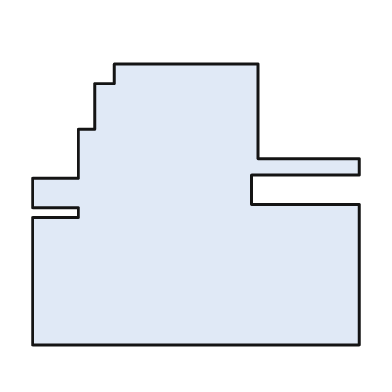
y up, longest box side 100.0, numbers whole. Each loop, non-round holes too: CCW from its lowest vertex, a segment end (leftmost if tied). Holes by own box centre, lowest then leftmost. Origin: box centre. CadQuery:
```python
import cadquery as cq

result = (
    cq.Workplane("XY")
    .moveTo(-50.0, -43.0)
    .lineTo(50.0, -43.0)
    .lineTo(50.0, 0.0)
    .lineTo(17.0, 0.0)
    .lineTo(17.0, 9.0)
    .lineTo(50.0, 9.0)
    .lineTo(50.0, 14.0)
    .lineTo(19.0, 14.0)
    .lineTo(19.0, 43.0)
    .lineTo(-25.0, 43.0)
    .lineTo(-25.0, 37.0)
    .lineTo(-31.0, 37.0)
    .lineTo(-31.0, 23.0)
    .lineTo(-36.0, 23.0)
    .lineTo(-36.0, 8.0)
    .lineTo(-50.0, 8.0)
    .lineTo(-50.0, -1.0)
    .lineTo(-36.0, -1.0)
    .lineTo(-36.0, -4.0)
    .lineTo(-50.0, -4.0)
    .close()
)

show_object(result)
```